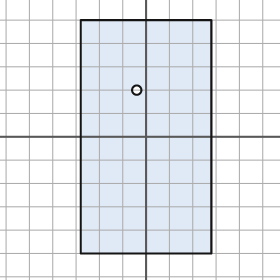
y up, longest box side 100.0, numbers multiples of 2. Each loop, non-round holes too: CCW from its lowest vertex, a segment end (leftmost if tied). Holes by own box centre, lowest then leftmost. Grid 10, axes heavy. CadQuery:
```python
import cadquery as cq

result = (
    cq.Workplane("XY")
    .moveTo(-28.0, -50.0)
    .lineTo(28.0, -50.0)
    .lineTo(28.0, 50.0)
    .lineTo(-28.0, 50.0)
    .close()
    .moveTo(-4.0, 20.0)
    .circle(2.0)
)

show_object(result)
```